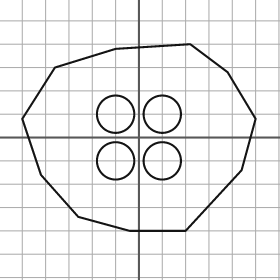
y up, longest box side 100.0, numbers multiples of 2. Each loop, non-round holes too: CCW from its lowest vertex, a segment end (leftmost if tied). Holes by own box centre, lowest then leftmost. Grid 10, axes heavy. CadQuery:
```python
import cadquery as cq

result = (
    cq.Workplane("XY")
    .moveTo(-4.0, -40.0)
    .lineTo(20.0, -40.0)
    .lineTo(44.0, -14.0)
    .lineTo(50.0, 8.0)
    .lineTo(38.0, 28.0)
    .lineTo(22.0, 40.0)
    .lineTo(-10.0, 38.0)
    .lineTo(-36.0, 30.0)
    .lineTo(-50.0, 8.0)
    .lineTo(-42.0, -16.0)
    .lineTo(-26.0, -34.0)
    .close()
    .moveTo(-10.0, -10.0)
    .circle(8.0)
    .moveTo(10.0, -10.0)
    .circle(8.0)
    .moveTo(-10.0, 10.0)
    .circle(8.0)
    .moveTo(10.0, 10.0)
    .circle(8.0)
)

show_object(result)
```